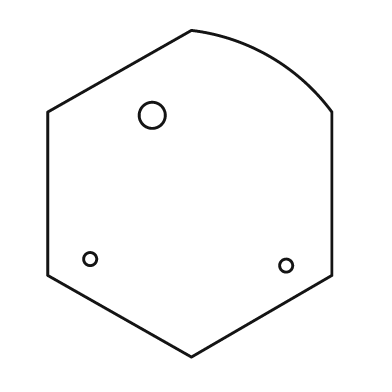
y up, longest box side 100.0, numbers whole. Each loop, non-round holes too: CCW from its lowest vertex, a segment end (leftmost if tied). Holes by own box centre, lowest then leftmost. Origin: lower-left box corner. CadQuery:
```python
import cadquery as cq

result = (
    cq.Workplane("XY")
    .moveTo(44.0, 0.0)
    .lineTo(87.0, 25.0)
    .lineTo(87.0, 75.0)
    .threePointArc((68.0, 92.0), (44.0, 100.0))
    .lineTo(0.0, 75.0)
    .lineTo(0.0, 25.0)
    .close()
    .moveTo(73.0, 28.0)
    .circle(2.0)
    .moveTo(13.0, 30.0)
    .circle(2.0)
    .moveTo(32.0, 74.0)
    .circle(4.0)
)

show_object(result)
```